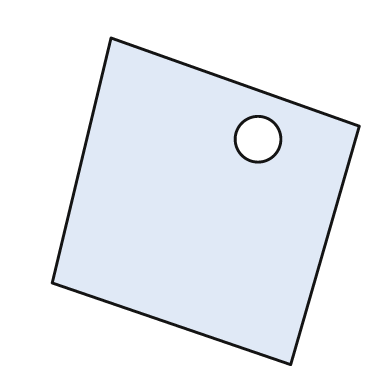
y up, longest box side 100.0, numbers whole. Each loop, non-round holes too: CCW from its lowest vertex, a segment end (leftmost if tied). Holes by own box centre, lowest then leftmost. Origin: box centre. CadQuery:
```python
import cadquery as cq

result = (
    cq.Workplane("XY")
    .moveTo(26.0, -50.0)
    .lineTo(47.0, 23.0)
    .lineTo(-29.0, 50.0)
    .lineTo(-47.0, -25.0)
    .close()
    .moveTo(16.0, 19.0)
    .circle(7.0)
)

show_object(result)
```